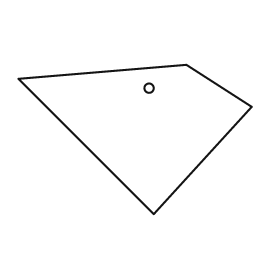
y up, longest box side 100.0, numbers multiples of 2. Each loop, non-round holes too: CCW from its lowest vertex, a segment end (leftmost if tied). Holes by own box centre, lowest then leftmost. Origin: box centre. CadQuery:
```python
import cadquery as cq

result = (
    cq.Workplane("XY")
    .moveTo(8.0, -32.0)
    .lineTo(50.0, 14.0)
    .lineTo(22.0, 32.0)
    .lineTo(-50.0, 26.0)
    .close()
    .moveTo(6.0, 22.0)
    .circle(2.0)
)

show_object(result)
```